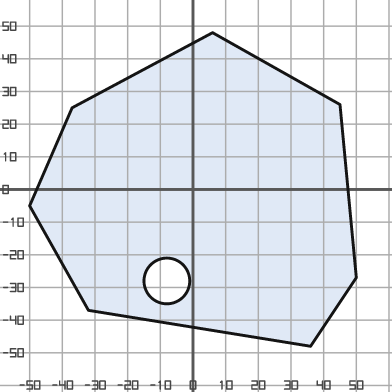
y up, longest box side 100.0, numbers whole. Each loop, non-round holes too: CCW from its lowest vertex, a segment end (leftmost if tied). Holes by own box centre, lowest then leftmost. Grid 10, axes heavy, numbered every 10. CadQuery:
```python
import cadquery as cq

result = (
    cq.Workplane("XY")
    .moveTo(36.0, -48.0)
    .lineTo(50.0, -27.0)
    .lineTo(45.0, 26.0)
    .lineTo(6.0, 48.0)
    .lineTo(-37.0, 25.0)
    .lineTo(-50.0, -5.0)
    .lineTo(-32.0, -37.0)
    .close()
    .moveTo(-8.0, -28.0)
    .circle(7.0)
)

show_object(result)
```